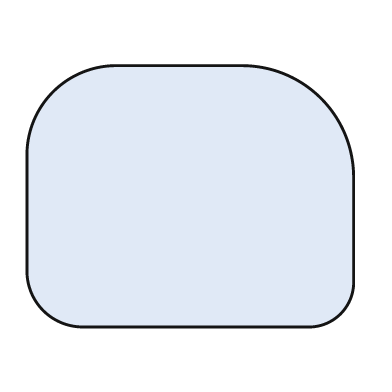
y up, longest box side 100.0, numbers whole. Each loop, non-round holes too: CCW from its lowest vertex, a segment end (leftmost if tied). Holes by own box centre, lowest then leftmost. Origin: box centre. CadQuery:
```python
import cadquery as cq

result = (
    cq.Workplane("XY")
    .moveTo(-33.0, -40.0)
    .lineTo(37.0, -40.0)
    .threePointArc((46.0, -36.0), (50.0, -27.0))
    .lineTo(50.0, 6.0)
    .threePointArc((40.0, 30.0), (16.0, 40.0))
    .lineTo(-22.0, 40.0)
    .threePointArc((-42.0, 32.0), (-50.0, 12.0))
    .lineTo(-50.0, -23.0)
    .threePointArc((-45.0, -35.0), (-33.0, -40.0))
    .close()
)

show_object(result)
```